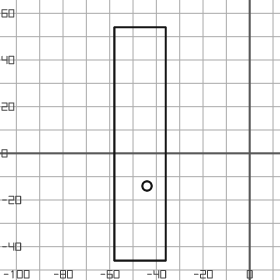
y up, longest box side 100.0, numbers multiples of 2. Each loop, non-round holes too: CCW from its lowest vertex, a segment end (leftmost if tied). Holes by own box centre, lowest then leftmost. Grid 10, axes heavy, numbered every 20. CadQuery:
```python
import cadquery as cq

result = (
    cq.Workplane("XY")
    .moveTo(-58.0, -46.0)
    .lineTo(-36.0, -46.0)
    .lineTo(-36.0, 54.0)
    .lineTo(-58.0, 54.0)
    .close()
    .moveTo(-44.0, -14.0)
    .circle(2.0)
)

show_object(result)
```